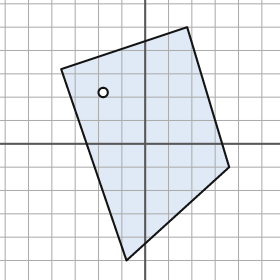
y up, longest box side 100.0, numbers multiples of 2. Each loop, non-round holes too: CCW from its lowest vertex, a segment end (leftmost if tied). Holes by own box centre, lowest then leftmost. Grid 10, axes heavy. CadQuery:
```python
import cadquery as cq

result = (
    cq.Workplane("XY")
    .moveTo(-8.0, -50.0)
    .lineTo(36.0, -10.0)
    .lineTo(18.0, 50.0)
    .lineTo(-36.0, 32.0)
    .close()
    .moveTo(-18.0, 22.0)
    .circle(2.0)
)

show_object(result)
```